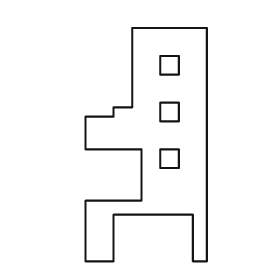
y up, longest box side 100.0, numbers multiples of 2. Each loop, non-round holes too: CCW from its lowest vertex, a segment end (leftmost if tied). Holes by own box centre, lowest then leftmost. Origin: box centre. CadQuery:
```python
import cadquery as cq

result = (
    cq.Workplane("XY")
    .moveTo(-26.0, -50.0)
    .lineTo(-14.0, -50.0)
    .lineTo(-14.0, -30.0)
    .lineTo(20.0, -30.0)
    .lineTo(20.0, -50.0)
    .lineTo(26.0, -50.0)
    .lineTo(26.0, 50.0)
    .lineTo(-6.0, 50.0)
    .lineTo(-6.0, 16.0)
    .lineTo(-14.0, 16.0)
    .lineTo(-14.0, 12.0)
    .lineTo(-26.0, 12.0)
    .lineTo(-26.0, -2.0)
    .lineTo(-2.0, -2.0)
    .lineTo(-2.0, -24.0)
    .lineTo(-26.0, -24.0)
    .close()
    .moveTo(6.0, -10.0)
    .lineTo(14.0, -10.0)
    .lineTo(14.0, -2.0)
    .lineTo(6.0, -2.0)
    .close()
    .moveTo(6.0, 10.0)
    .lineTo(14.0, 10.0)
    .lineTo(14.0, 18.0)
    .lineTo(6.0, 18.0)
    .close()
    .moveTo(6.0, 30.0)
    .lineTo(14.0, 30.0)
    .lineTo(14.0, 38.0)
    .lineTo(6.0, 38.0)
    .close()
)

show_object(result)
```